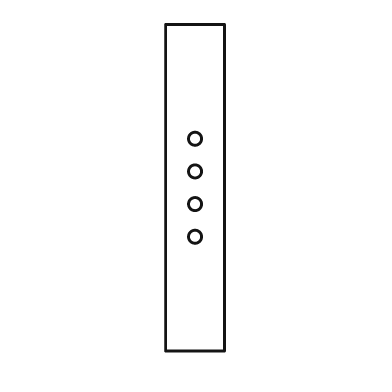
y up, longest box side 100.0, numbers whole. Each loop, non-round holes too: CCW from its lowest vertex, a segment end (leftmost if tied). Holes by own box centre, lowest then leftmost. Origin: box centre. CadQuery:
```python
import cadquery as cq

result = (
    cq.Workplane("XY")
    .moveTo(-9.0, -50.0)
    .lineTo(9.0, -50.0)
    .lineTo(9.0, 50.0)
    .lineTo(-9.0, 50.0)
    .close()
    .moveTo(0.0, -15.0)
    .circle(2.0)
    .moveTo(0.0, -5.0)
    .circle(2.0)
    .moveTo(0.0, 5.0)
    .circle(2.0)
    .moveTo(0.0, 15.0)
    .circle(2.0)
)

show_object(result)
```